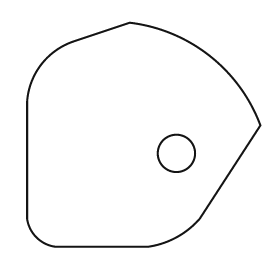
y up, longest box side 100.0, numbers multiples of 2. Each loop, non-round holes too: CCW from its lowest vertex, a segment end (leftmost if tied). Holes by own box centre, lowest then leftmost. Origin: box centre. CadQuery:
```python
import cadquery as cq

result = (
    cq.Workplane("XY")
    .moveTo(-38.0, -48.0)
    .lineTo(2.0, -48.0)
    .threePointArc((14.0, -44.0), (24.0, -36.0))
    .lineTo(50.0, 4.0)
    .threePointArc((28.0, 34.0), (-6.0, 48.0))
    .lineTo(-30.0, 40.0)
    .threePointArc((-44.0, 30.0), (-50.0, 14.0))
    .lineTo(-50.0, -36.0)
    .threePointArc((-46.0, -44.0), (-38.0, -48.0))
    .close()
    .moveTo(14.0, -8.0)
    .circle(8.0)
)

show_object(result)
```